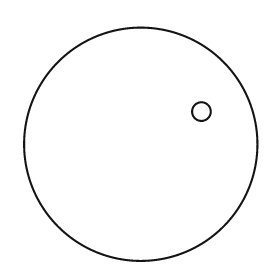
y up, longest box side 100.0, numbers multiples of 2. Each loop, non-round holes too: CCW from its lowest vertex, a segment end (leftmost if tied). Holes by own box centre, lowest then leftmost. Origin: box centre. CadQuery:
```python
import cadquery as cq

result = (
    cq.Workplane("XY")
    .moveTo(0.0, 0.0)
    .circle(50.0)
    .moveTo(26.0, 14.0)
    .circle(4.0)
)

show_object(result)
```